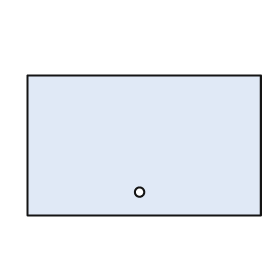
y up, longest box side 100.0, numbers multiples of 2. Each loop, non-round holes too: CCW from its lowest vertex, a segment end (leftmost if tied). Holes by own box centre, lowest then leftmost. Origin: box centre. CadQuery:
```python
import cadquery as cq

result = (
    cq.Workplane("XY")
    .moveTo(-50.0, -30.0)
    .lineTo(50.0, -30.0)
    .lineTo(50.0, 30.0)
    .lineTo(-50.0, 30.0)
    .close()
    .moveTo(-2.0, -20.0)
    .circle(2.0)
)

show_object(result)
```